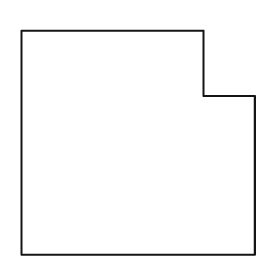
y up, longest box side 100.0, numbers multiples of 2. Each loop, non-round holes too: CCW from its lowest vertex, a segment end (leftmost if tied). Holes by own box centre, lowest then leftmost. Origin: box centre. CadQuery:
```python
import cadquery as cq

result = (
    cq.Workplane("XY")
    .moveTo(-50.0, -48.0)
    .lineTo(50.0, -48.0)
    .lineTo(50.0, 20.0)
    .lineTo(28.0, 20.0)
    .lineTo(28.0, 48.0)
    .lineTo(-50.0, 48.0)
    .close()
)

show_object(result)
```